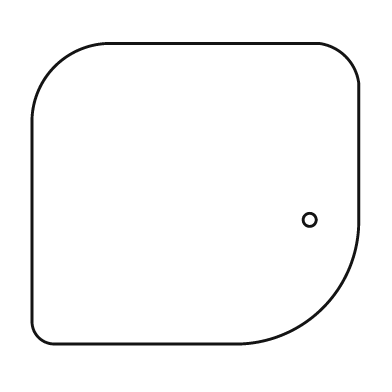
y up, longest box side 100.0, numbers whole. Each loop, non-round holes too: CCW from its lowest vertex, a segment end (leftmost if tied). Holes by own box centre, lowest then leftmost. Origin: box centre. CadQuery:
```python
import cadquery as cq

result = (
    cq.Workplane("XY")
    .moveTo(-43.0, -46.0)
    .lineTo(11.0, -46.0)
    .threePointArc((39.0, -35.0), (50.0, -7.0))
    .lineTo(50.0, 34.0)
    .threePointArc((46.0, 42.0), (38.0, 46.0))
    .lineTo(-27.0, 46.0)
    .threePointArc((-43.0, 39.0), (-50.0, 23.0))
    .lineTo(-50.0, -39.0)
    .threePointArc((-48.0, -44.0), (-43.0, -46.0))
    .close()
    .moveTo(35.0, -8.0)
    .circle(2.0)
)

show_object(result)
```